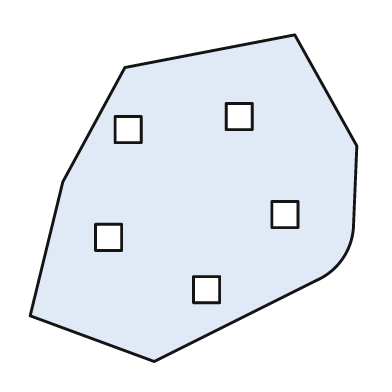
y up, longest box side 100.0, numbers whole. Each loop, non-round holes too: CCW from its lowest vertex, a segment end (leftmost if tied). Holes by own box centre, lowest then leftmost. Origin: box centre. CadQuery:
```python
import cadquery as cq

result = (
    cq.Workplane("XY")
    .moveTo(-12.0, -50.0)
    .lineTo(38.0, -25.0)
    .threePointArc((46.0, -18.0), (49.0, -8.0))
    .lineTo(50.0, 16.0)
    .lineTo(31.0, 50.0)
    .lineTo(-21.0, 40.0)
    .lineTo(-40.0, 5.0)
    .lineTo(-50.0, -36.0)
    .close()
    .moveTo(0.0, -32.0)
    .lineTo(8.0, -32.0)
    .lineTo(8.0, -24.0)
    .lineTo(0.0, -24.0)
    .close()
    .moveTo(-30.0, -16.0)
    .lineTo(-22.0, -16.0)
    .lineTo(-22.0, -8.0)
    .lineTo(-30.0, -8.0)
    .close()
    .moveTo(24.0, -9.0)
    .lineTo(32.0, -9.0)
    .lineTo(32.0, -1.0)
    .lineTo(24.0, -1.0)
    .close()
    .moveTo(-24.0, 17.0)
    .lineTo(-16.0, 17.0)
    .lineTo(-16.0, 25.0)
    .lineTo(-24.0, 25.0)
    .close()
    .moveTo(10.0, 21.0)
    .lineTo(18.0, 21.0)
    .lineTo(18.0, 29.0)
    .lineTo(10.0, 29.0)
    .close()
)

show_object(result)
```